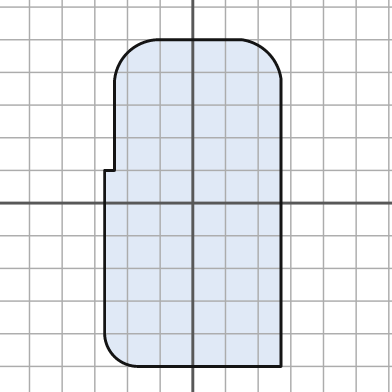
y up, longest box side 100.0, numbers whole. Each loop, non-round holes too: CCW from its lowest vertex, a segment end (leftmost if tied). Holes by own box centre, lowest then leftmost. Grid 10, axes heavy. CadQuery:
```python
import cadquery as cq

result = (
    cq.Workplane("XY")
    .moveTo(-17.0, -50.0)
    .lineTo(27.0, -50.0)
    .lineTo(27.0, 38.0)
    .threePointArc((23.0, 46.0), (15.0, 50.0))
    .lineTo(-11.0, 50.0)
    .threePointArc((-20.0, 46.0), (-24.0, 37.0))
    .lineTo(-24.0, 10.0)
    .lineTo(-27.0, 10.0)
    .lineTo(-27.0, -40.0)
    .threePointArc((-24.0, -47.0), (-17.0, -50.0))
    .close()
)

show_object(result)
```